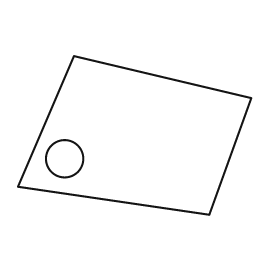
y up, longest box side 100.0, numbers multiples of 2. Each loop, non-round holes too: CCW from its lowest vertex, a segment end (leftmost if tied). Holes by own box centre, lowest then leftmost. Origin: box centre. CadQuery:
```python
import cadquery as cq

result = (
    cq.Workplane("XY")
    .moveTo(32.0, -34.0)
    .lineTo(50.0, 16.0)
    .lineTo(-26.0, 34.0)
    .lineTo(-50.0, -22.0)
    .close()
    .moveTo(-30.0, -10.0)
    .circle(8.0)
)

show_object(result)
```